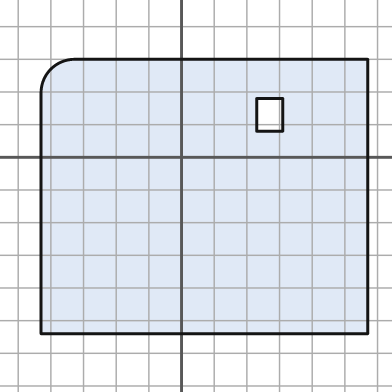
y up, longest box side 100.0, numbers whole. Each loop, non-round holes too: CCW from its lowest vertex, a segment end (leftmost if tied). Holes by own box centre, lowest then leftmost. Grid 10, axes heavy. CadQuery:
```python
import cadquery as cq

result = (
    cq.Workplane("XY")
    .moveTo(-43.0, -54.0)
    .lineTo(57.0, -54.0)
    .lineTo(57.0, 30.0)
    .lineTo(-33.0, 30.0)
    .threePointArc((-40.0, 27.0), (-43.0, 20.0))
    .close()
    .moveTo(23.0, 8.0)
    .lineTo(31.0, 8.0)
    .lineTo(31.0, 18.0)
    .lineTo(23.0, 18.0)
    .close()
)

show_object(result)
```